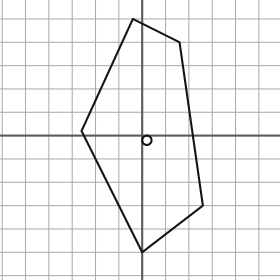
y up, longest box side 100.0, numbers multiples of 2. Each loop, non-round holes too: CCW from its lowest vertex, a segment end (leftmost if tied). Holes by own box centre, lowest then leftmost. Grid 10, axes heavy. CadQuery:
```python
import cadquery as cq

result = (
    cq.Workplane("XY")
    .moveTo(0.0, -50.0)
    .lineTo(26.0, -30.0)
    .lineTo(16.0, 40.0)
    .lineTo(-4.0, 50.0)
    .lineTo(-26.0, 2.0)
    .close()
    .moveTo(2.0, -2.0)
    .circle(2.0)
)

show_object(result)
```